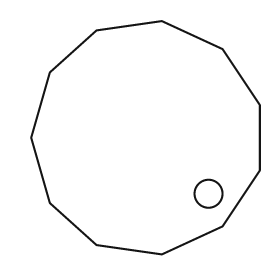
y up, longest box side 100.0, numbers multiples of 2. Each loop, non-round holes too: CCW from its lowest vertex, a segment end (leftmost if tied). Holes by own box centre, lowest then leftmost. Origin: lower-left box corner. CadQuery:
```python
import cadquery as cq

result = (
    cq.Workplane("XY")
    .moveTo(56.0, 0.0)
    .lineTo(82.0, 12.0)
    .lineTo(98.0, 36.0)
    .lineTo(98.0, 64.0)
    .lineTo(82.0, 88.0)
    .lineTo(56.0, 100.0)
    .lineTo(28.0, 96.0)
    .lineTo(8.0, 78.0)
    .lineTo(0.0, 50.0)
    .lineTo(8.0, 22.0)
    .lineTo(28.0, 4.0)
    .close()
    .moveTo(76.0, 26.0)
    .circle(6.0)
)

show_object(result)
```